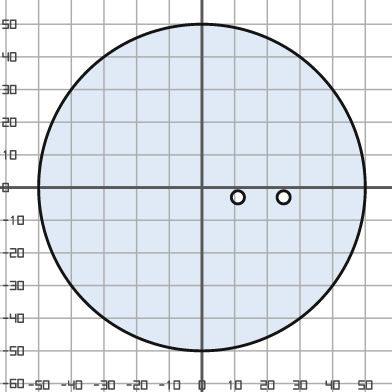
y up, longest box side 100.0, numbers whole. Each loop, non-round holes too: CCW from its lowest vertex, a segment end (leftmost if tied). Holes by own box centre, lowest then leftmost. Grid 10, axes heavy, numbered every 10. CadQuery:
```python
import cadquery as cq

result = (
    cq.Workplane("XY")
    .moveTo(0.0, 0.0)
    .circle(50.0)
    .moveTo(11.0, -3.0)
    .circle(2.0)
    .moveTo(25.0, -3.0)
    .circle(2.0)
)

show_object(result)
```